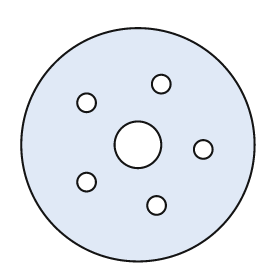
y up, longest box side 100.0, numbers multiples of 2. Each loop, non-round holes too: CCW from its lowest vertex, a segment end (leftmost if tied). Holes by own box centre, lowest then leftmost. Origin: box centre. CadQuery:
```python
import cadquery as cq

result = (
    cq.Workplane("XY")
    .moveTo(0.0, 0.0)
    .circle(50.0)
    .moveTo(8.0, -26.0)
    .circle(4.0)
    .moveTo(-22.0, -16.0)
    .circle(4.0)
    .moveTo(28.0, -2.0)
    .circle(4.0)
    .moveTo(0.0, 0.0)
    .circle(10.0)
    .moveTo(-22.0, 18.0)
    .circle(4.0)
    .moveTo(10.0, 26.0)
    .circle(4.0)
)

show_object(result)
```